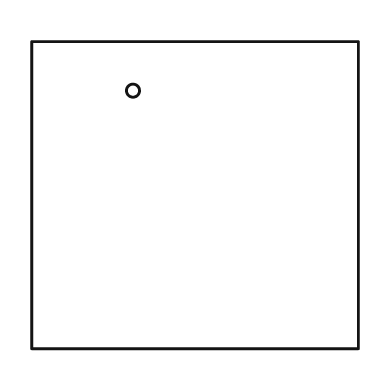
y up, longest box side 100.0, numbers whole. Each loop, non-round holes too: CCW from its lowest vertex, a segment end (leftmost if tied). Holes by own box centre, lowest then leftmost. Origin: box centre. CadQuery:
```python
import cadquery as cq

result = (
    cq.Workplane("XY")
    .moveTo(-50.0, -47.0)
    .lineTo(50.0, -47.0)
    .lineTo(50.0, 47.0)
    .lineTo(-50.0, 47.0)
    .close()
    .moveTo(-19.0, 32.0)
    .circle(2.0)
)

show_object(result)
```